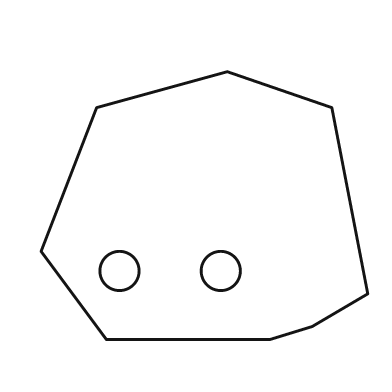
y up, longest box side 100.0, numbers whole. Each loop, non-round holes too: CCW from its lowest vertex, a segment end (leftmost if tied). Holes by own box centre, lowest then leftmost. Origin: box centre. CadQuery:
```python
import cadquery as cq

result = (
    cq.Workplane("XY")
    .moveTo(-30.0, -41.0)
    .lineTo(20.0, -41.0)
    .lineTo(33.0, -37.0)
    .lineTo(50.0, -27.0)
    .lineTo(39.0, 30.0)
    .lineTo(7.0, 41.0)
    .lineTo(-33.0, 30.0)
    .lineTo(-50.0, -14.0)
    .close()
    .moveTo(-26.0, -20.0)
    .circle(6.0)
    .moveTo(5.0, -20.0)
    .circle(6.0)
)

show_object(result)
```